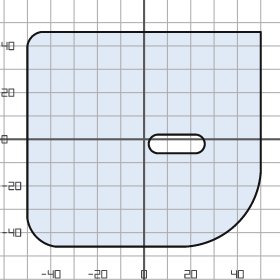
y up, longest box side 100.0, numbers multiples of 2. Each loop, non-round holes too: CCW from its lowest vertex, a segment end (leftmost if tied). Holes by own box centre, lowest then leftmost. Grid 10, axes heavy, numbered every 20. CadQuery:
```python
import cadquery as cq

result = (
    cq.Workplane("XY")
    .moveTo(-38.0, -46.0)
    .lineTo(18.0, -46.0)
    .threePointArc((40.0, -36.0), (50.0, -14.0))
    .lineTo(50.0, 46.0)
    .lineTo(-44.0, 46.0)
    .threePointArc((-48.0, 44.0), (-50.0, 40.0))
    .lineTo(-50.0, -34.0)
    .threePointArc((-46.0, -42.0), (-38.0, -46.0))
    .close()
    .moveTo(6.0, -6.0)
    .lineTo(22.0, -6.0)
    .threePointArc((26.0, -2.0), (22.0, 2.0))
    .lineTo(6.0, 2.0)
    .threePointArc((2.0, -2.0), (6.0, -6.0))
    .close()
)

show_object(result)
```